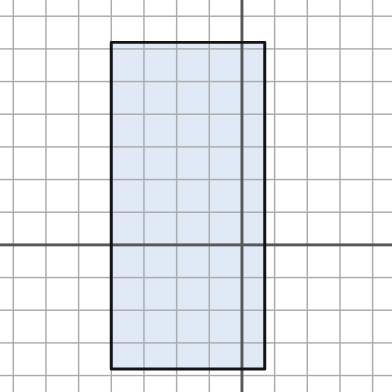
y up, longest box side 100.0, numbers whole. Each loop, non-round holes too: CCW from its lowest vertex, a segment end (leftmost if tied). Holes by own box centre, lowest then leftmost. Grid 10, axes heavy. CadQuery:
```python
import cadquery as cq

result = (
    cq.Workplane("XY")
    .moveTo(-40.0, -38.0)
    .lineTo(7.0, -38.0)
    .lineTo(7.0, 62.0)
    .lineTo(-40.0, 62.0)
    .close()
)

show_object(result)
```